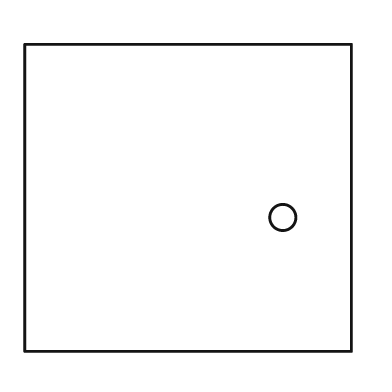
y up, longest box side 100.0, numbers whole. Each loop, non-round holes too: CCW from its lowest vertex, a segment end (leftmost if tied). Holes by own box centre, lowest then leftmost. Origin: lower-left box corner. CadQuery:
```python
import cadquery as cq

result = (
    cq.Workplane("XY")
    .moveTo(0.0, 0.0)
    .lineTo(100.0, 0.0)
    .lineTo(100.0, 94.0)
    .lineTo(0.0, 94.0)
    .close()
    .moveTo(79.0, 41.0)
    .circle(4.0)
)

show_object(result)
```